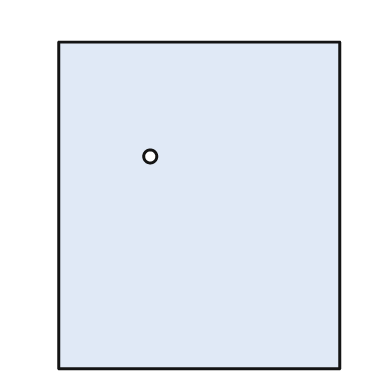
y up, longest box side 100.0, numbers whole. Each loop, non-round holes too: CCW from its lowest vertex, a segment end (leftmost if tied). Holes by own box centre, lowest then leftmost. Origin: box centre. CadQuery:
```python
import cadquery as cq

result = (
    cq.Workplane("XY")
    .moveTo(-43.0, -50.0)
    .lineTo(43.0, -50.0)
    .lineTo(43.0, 50.0)
    .lineTo(-43.0, 50.0)
    .close()
    .moveTo(-15.0, 15.0)
    .circle(2.0)
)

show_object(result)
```